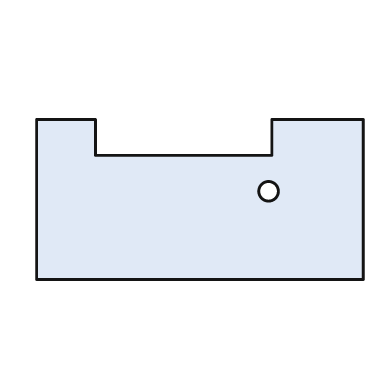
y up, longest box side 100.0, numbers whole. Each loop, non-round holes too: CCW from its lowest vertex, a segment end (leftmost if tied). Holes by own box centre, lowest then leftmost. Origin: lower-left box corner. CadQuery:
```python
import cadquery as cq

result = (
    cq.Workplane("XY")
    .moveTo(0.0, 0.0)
    .lineTo(100.0, 0.0)
    .lineTo(100.0, 49.0)
    .lineTo(72.0, 49.0)
    .lineTo(72.0, 38.0)
    .lineTo(18.0, 38.0)
    .lineTo(18.0, 49.0)
    .lineTo(0.0, 49.0)
    .close()
    .moveTo(71.0, 27.0)
    .circle(3.0)
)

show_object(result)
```